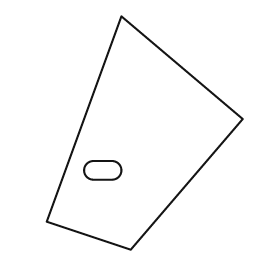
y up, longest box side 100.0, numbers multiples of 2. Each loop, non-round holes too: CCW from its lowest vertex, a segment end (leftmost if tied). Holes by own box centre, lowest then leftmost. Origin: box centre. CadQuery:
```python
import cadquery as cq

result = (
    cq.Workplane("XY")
    .moveTo(-6.0, -50.0)
    .lineTo(42.0, 6.0)
    .lineTo(-10.0, 50.0)
    .lineTo(-42.0, -38.0)
    .close()
    .moveTo(-22.0, -20.0)
    .lineTo(-14.0, -20.0)
    .threePointArc((-10.0, -16.0), (-14.0, -12.0))
    .lineTo(-22.0, -12.0)
    .threePointArc((-26.0, -16.0), (-22.0, -20.0))
    .close()
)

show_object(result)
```